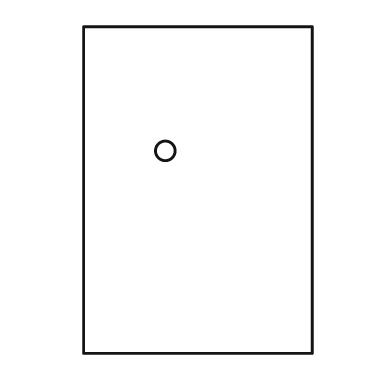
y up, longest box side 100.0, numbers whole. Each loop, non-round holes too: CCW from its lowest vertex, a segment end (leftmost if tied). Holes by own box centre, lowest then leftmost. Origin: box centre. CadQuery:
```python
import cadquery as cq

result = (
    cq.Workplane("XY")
    .moveTo(-35.0, -50.0)
    .lineTo(35.0, -50.0)
    .lineTo(35.0, 50.0)
    .lineTo(-35.0, 50.0)
    .close()
    .moveTo(-10.0, 12.0)
    .circle(3.0)
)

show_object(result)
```